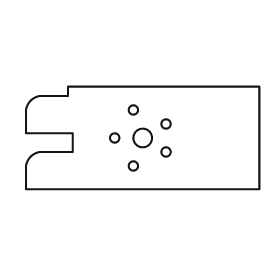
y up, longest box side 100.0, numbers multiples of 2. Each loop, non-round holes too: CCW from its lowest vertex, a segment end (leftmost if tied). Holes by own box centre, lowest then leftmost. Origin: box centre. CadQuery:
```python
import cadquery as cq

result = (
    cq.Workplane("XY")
    .moveTo(-50.0, -22.0)
    .lineTo(50.0, -22.0)
    .lineTo(50.0, 22.0)
    .lineTo(-32.0, 22.0)
    .lineTo(-32.0, 18.0)
    .lineTo(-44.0, 18.0)
    .threePointArc((-48.0, 16.0), (-50.0, 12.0))
    .lineTo(-50.0, 2.0)
    .lineTo(-30.0, 2.0)
    .lineTo(-30.0, -6.0)
    .lineTo(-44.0, -6.0)
    .threePointArc((-48.0, -8.0), (-50.0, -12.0))
    .close()
    .moveTo(-4.0, -12.0)
    .circle(2.0)
    .moveTo(10.0, -6.0)
    .circle(2.0)
    .moveTo(-12.0, 0.0)
    .circle(2.0)
    .moveTo(0.0, 0.0)
    .circle(4.0)
    .moveTo(10.0, 6.0)
    .circle(2.0)
    .moveTo(-4.0, 12.0)
    .circle(2.0)
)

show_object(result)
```